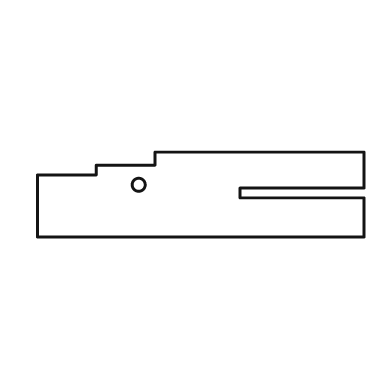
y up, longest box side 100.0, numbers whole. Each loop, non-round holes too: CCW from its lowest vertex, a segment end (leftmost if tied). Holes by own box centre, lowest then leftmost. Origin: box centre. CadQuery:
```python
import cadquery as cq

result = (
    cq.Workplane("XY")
    .moveTo(-50.0, -13.0)
    .lineTo(50.0, -13.0)
    .lineTo(50.0, -1.0)
    .lineTo(12.0, -1.0)
    .lineTo(12.0, 2.0)
    .lineTo(50.0, 2.0)
    .lineTo(50.0, 13.0)
    .lineTo(-14.0, 13.0)
    .lineTo(-14.0, 9.0)
    .lineTo(-32.0, 9.0)
    .lineTo(-32.0, 6.0)
    .lineTo(-50.0, 6.0)
    .close()
    .moveTo(-19.0, 3.0)
    .circle(2.0)
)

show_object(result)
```